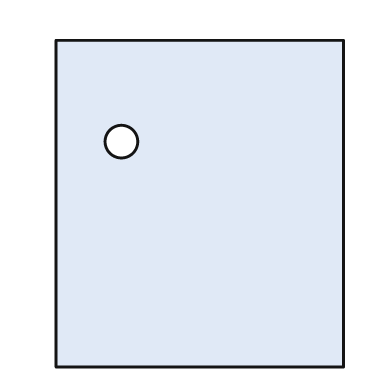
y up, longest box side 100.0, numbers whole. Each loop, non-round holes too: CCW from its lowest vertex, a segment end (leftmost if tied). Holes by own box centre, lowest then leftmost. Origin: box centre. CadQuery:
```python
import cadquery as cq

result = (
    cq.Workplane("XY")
    .moveTo(-44.0, -50.0)
    .lineTo(44.0, -50.0)
    .lineTo(44.0, 50.0)
    .lineTo(-44.0, 50.0)
    .close()
    .moveTo(-24.0, 19.0)
    .circle(5.0)
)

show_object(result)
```